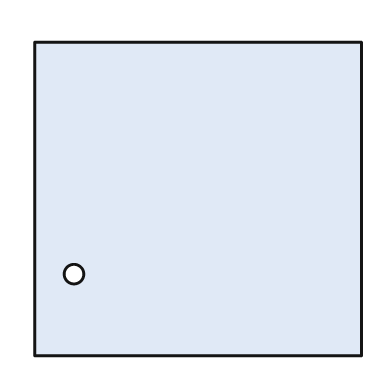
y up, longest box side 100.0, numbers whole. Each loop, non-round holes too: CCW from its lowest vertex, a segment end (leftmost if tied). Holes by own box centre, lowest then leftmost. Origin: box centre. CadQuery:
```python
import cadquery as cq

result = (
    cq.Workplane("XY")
    .moveTo(-50.0, -48.0)
    .lineTo(50.0, -48.0)
    .lineTo(50.0, 48.0)
    .lineTo(-50.0, 48.0)
    .close()
    .moveTo(-38.0, -23.0)
    .circle(3.0)
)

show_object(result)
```